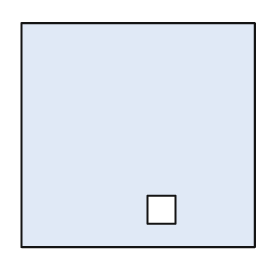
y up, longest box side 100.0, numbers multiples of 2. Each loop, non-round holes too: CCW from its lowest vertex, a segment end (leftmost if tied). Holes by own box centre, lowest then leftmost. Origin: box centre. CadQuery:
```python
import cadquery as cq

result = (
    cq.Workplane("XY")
    .moveTo(-50.0, -48.0)
    .lineTo(50.0, -48.0)
    .lineTo(50.0, 48.0)
    .lineTo(-50.0, 48.0)
    .close()
    .moveTo(4.0, -38.0)
    .lineTo(16.0, -38.0)
    .lineTo(16.0, -26.0)
    .lineTo(4.0, -26.0)
    .close()
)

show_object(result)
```